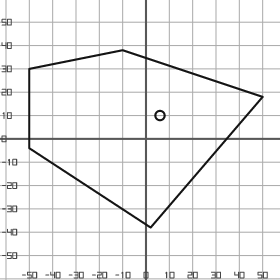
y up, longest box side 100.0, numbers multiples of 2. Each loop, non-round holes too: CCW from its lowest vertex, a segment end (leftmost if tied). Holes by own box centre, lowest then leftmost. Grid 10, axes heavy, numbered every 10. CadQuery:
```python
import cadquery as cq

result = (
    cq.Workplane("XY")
    .moveTo(2.0, -38.0)
    .lineTo(50.0, 18.0)
    .lineTo(-10.0, 38.0)
    .lineTo(-50.0, 30.0)
    .lineTo(-50.0, -4.0)
    .close()
    .moveTo(6.0, 10.0)
    .circle(2.0)
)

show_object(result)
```